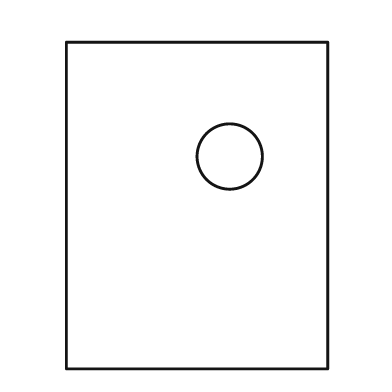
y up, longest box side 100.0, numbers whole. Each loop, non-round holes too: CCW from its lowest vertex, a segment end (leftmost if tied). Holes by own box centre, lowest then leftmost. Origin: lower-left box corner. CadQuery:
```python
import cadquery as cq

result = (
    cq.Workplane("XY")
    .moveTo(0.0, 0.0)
    .lineTo(80.0, 0.0)
    .lineTo(80.0, 100.0)
    .lineTo(0.0, 100.0)
    .close()
    .moveTo(50.0, 65.0)
    .circle(10.0)
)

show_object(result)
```